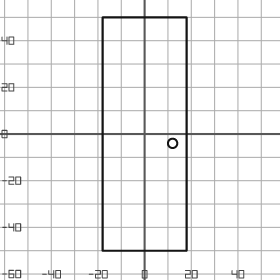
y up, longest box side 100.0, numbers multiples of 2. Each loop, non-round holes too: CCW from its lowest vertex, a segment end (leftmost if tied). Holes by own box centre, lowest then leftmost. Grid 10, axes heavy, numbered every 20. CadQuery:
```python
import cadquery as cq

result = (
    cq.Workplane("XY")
    .moveTo(-18.0, -50.0)
    .lineTo(18.0, -50.0)
    .lineTo(18.0, 50.0)
    .lineTo(-18.0, 50.0)
    .close()
    .moveTo(12.0, -4.0)
    .circle(2.0)
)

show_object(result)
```